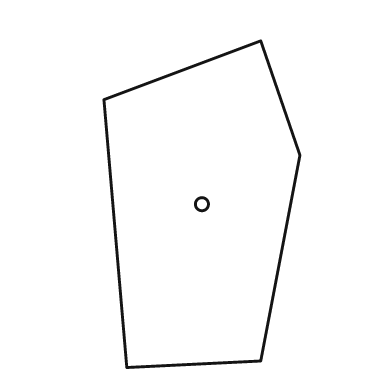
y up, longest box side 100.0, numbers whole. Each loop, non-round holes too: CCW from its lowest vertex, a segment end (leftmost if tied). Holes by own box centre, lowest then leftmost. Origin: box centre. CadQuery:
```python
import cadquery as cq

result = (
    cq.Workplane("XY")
    .moveTo(-23.0, -50.0)
    .lineTo(18.0, -48.0)
    .lineTo(30.0, 15.0)
    .lineTo(18.0, 50.0)
    .lineTo(-30.0, 32.0)
    .close()
    .moveTo(0.0, 0.0)
    .circle(2.0)
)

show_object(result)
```